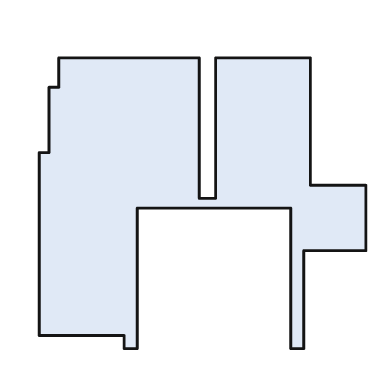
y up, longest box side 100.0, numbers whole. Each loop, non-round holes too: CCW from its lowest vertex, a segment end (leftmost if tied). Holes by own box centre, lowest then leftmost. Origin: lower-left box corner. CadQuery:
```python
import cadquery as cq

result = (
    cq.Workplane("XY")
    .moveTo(26.0, 0.0)
    .lineTo(30.0, 0.0)
    .lineTo(30.0, 43.0)
    .lineTo(77.0, 43.0)
    .lineTo(77.0, 0.0)
    .lineTo(81.0, 0.0)
    .lineTo(81.0, 30.0)
    .lineTo(100.0, 30.0)
    .lineTo(100.0, 50.0)
    .lineTo(83.0, 50.0)
    .lineTo(83.0, 89.0)
    .lineTo(54.0, 89.0)
    .lineTo(54.0, 46.0)
    .lineTo(49.0, 46.0)
    .lineTo(49.0, 89.0)
    .lineTo(6.0, 89.0)
    .lineTo(6.0, 80.0)
    .lineTo(3.0, 80.0)
    .lineTo(3.0, 60.0)
    .lineTo(0.0, 60.0)
    .lineTo(0.0, 4.0)
    .lineTo(26.0, 4.0)
    .close()
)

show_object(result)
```